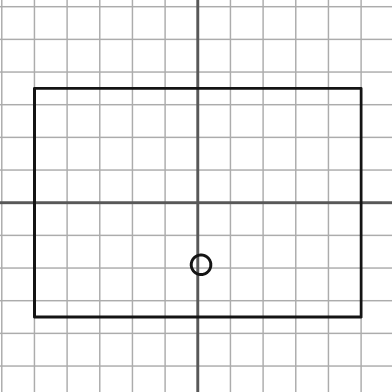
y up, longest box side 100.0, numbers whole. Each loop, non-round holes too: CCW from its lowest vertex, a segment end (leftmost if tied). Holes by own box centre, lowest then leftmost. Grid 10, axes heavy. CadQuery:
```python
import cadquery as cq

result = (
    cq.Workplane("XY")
    .moveTo(-50.0, -35.0)
    .lineTo(50.0, -35.0)
    .lineTo(50.0, 35.0)
    .lineTo(-50.0, 35.0)
    .close()
    .moveTo(1.0, -19.0)
    .circle(3.0)
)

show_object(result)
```